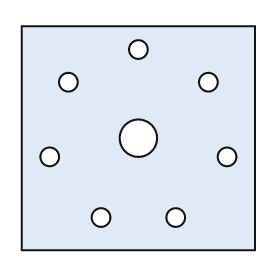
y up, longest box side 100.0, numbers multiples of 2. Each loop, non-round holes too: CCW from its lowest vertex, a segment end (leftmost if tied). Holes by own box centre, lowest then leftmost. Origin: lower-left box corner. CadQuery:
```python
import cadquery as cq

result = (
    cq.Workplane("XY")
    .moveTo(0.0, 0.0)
    .lineTo(100.0, 0.0)
    .lineTo(100.0, 96.0)
    .lineTo(0.0, 96.0)
    .close()
    .moveTo(34.0, 14.0)
    .circle(4.0)
    .moveTo(66.0, 14.0)
    .circle(4.0)
    .moveTo(12.0, 40.0)
    .circle(4.0)
    .moveTo(88.0, 40.0)
    .circle(4.0)
    .moveTo(50.0, 48.0)
    .circle(8.0)
    .moveTo(20.0, 72.0)
    .circle(4.0)
    .moveTo(80.0, 72.0)
    .circle(4.0)
    .moveTo(50.0, 86.0)
    .circle(4.0)
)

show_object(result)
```